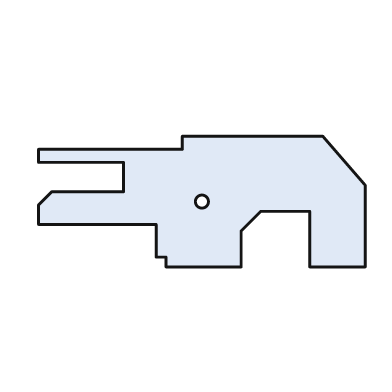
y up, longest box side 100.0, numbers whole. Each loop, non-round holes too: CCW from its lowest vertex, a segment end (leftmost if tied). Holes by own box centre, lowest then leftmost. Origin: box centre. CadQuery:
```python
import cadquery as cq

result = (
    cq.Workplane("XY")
    .moveTo(-11.0, -20.0)
    .lineTo(12.0, -20.0)
    .lineTo(12.0, -9.0)
    .lineTo(18.0, -3.0)
    .lineTo(33.0, -3.0)
    .lineTo(33.0, -20.0)
    .lineTo(50.0, -20.0)
    .lineTo(50.0, 5.0)
    .lineTo(37.0, 20.0)
    .lineTo(-6.0, 20.0)
    .lineTo(-6.0, 16.0)
    .lineTo(-50.0, 16.0)
    .lineTo(-50.0, 12.0)
    .lineTo(-24.0, 12.0)
    .lineTo(-24.0, 3.0)
    .lineTo(-46.0, 3.0)
    .lineTo(-50.0, -1.0)
    .lineTo(-50.0, -7.0)
    .lineTo(-14.0, -7.0)
    .lineTo(-14.0, -17.0)
    .lineTo(-11.0, -17.0)
    .close()
    .moveTo(0.0, 0.0)
    .circle(2.0)
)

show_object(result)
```